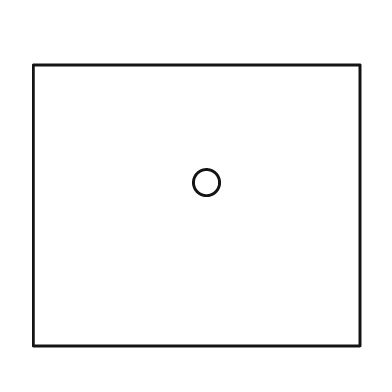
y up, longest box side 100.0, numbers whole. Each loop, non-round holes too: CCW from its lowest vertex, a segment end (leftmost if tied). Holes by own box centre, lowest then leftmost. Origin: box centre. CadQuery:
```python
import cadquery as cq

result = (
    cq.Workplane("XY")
    .moveTo(-50.0, -43.0)
    .lineTo(50.0, -43.0)
    .lineTo(50.0, 43.0)
    .lineTo(-50.0, 43.0)
    .close()
    .moveTo(3.0, 7.0)
    .circle(4.0)
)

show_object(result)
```